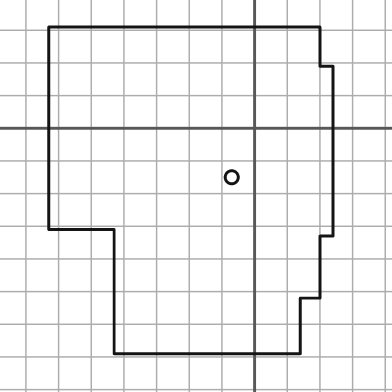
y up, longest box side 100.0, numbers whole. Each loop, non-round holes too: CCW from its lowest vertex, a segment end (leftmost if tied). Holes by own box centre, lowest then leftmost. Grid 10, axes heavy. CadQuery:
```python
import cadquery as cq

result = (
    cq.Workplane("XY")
    .moveTo(-43.0, -69.0)
    .lineTo(14.0, -69.0)
    .lineTo(14.0, -52.0)
    .lineTo(20.0, -52.0)
    .lineTo(20.0, -33.0)
    .lineTo(24.0, -33.0)
    .lineTo(24.0, 19.0)
    .lineTo(20.0, 19.0)
    .lineTo(20.0, 31.0)
    .lineTo(-63.0, 31.0)
    .lineTo(-63.0, -31.0)
    .lineTo(-43.0, -31.0)
    .close()
    .moveTo(-7.0, -15.0)
    .circle(2.0)
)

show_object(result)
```